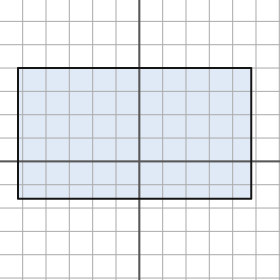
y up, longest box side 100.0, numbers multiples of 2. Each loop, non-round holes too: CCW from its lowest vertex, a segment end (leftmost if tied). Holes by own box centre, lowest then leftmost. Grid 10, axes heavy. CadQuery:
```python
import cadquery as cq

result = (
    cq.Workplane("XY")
    .moveTo(-52.0, -16.0)
    .lineTo(48.0, -16.0)
    .lineTo(48.0, 40.0)
    .lineTo(-52.0, 40.0)
    .close()
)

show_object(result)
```